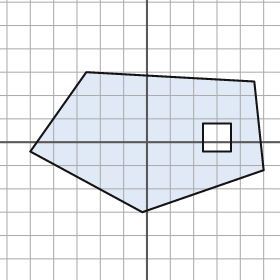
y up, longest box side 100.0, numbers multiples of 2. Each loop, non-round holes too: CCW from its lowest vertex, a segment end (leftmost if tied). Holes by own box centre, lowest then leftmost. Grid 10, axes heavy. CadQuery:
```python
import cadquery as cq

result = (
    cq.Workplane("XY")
    .moveTo(-2.0, -30.0)
    .lineTo(50.0, -12.0)
    .lineTo(46.0, 26.0)
    .lineTo(-26.0, 30.0)
    .lineTo(-50.0, -4.0)
    .close()
    .moveTo(24.0, -4.0)
    .lineTo(36.0, -4.0)
    .lineTo(36.0, 8.0)
    .lineTo(24.0, 8.0)
    .close()
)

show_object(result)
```